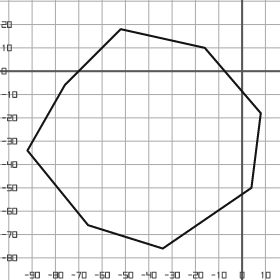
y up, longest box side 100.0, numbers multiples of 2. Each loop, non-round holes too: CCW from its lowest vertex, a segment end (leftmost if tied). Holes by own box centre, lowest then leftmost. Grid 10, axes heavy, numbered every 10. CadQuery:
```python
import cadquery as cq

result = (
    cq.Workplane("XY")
    .moveTo(-34.0, -76.0)
    .lineTo(4.0, -50.0)
    .lineTo(8.0, -18.0)
    .lineTo(-16.0, 10.0)
    .lineTo(-52.0, 18.0)
    .lineTo(-76.0, -6.0)
    .lineTo(-92.0, -34.0)
    .lineTo(-66.0, -66.0)
    .close()
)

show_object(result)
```